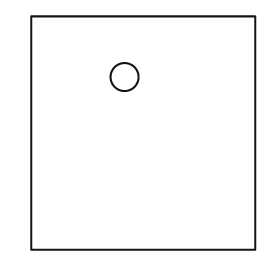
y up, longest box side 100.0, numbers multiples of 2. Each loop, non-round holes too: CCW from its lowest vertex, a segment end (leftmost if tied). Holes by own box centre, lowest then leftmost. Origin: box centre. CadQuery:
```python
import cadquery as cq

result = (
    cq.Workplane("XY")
    .moveTo(-48.0, -50.0)
    .lineTo(48.0, -50.0)
    .lineTo(48.0, 50.0)
    .lineTo(-48.0, 50.0)
    .close()
    .moveTo(-8.0, 24.0)
    .circle(6.0)
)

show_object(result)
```